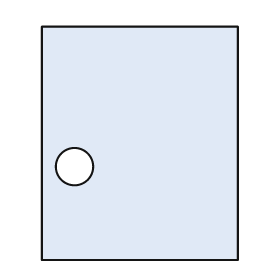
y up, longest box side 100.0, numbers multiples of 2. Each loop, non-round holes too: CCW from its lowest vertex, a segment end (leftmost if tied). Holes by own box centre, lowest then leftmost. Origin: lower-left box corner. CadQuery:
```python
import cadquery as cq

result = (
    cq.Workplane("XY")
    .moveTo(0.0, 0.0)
    .lineTo(84.0, 0.0)
    .lineTo(84.0, 100.0)
    .lineTo(0.0, 100.0)
    .close()
    .moveTo(14.0, 40.0)
    .circle(8.0)
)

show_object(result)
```